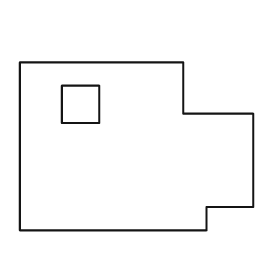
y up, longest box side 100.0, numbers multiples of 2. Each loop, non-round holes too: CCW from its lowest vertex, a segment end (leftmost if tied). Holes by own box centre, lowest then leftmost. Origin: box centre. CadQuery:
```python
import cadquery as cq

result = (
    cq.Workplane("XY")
    .moveTo(-50.0, -36.0)
    .lineTo(30.0, -36.0)
    .lineTo(30.0, -26.0)
    .lineTo(50.0, -26.0)
    .lineTo(50.0, 14.0)
    .lineTo(20.0, 14.0)
    .lineTo(20.0, 36.0)
    .lineTo(-50.0, 36.0)
    .close()
    .moveTo(-32.0, 10.0)
    .lineTo(-16.0, 10.0)
    .lineTo(-16.0, 26.0)
    .lineTo(-32.0, 26.0)
    .close()
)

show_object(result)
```